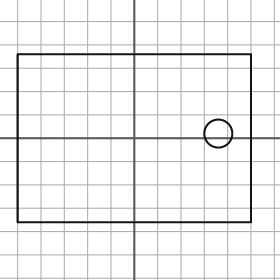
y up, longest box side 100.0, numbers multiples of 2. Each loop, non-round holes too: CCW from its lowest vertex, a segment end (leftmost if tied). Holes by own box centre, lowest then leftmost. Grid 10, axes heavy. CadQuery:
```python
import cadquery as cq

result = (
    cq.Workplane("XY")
    .moveTo(-50.0, -36.0)
    .lineTo(50.0, -36.0)
    .lineTo(50.0, 36.0)
    .lineTo(-50.0, 36.0)
    .close()
    .moveTo(36.0, 2.0)
    .circle(6.0)
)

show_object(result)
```